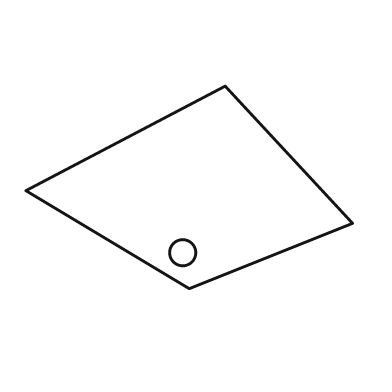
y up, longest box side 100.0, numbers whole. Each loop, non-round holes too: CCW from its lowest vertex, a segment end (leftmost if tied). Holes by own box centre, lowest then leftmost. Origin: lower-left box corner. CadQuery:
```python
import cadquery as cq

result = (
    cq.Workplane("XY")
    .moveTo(50.0, 0.0)
    .lineTo(100.0, 20.0)
    .lineTo(61.0, 62.0)
    .lineTo(0.0, 30.0)
    .close()
    .moveTo(48.0, 11.0)
    .circle(4.0)
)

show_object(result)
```